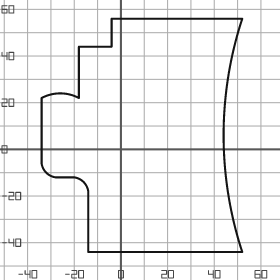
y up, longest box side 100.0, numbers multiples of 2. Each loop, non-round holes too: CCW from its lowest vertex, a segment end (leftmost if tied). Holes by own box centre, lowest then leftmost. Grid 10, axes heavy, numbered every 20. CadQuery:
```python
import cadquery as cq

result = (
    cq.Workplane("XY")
    .moveTo(-14.0, -44.0)
    .lineTo(52.0, -44.0)
    .threePointArc((44.0, 6.0), (52.0, 56.0))
    .lineTo(-4.0, 56.0)
    .lineTo(-4.0, 44.0)
    .lineTo(-18.0, 44.0)
    .lineTo(-18.0, 22.0)
    .threePointArc((-26.0, 24.0), (-34.0, 22.0))
    .lineTo(-34.0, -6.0)
    .threePointArc((-32.0, -10.0), (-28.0, -12.0))
    .lineTo(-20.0, -12.0)
    .threePointArc((-16.0, -14.0), (-14.0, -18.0))
    .close()
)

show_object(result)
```